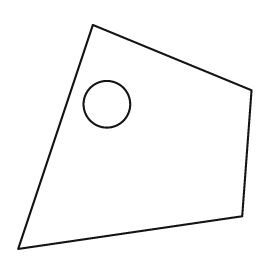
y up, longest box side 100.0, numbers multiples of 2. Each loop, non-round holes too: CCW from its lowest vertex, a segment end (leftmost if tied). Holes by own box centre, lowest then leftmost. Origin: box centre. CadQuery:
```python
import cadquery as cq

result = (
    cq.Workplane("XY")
    .moveTo(-50.0, -48.0)
    .lineTo(46.0, -34.0)
    .lineTo(50.0, 20.0)
    .lineTo(-18.0, 48.0)
    .close()
    .moveTo(-12.0, 14.0)
    .circle(10.0)
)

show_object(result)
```